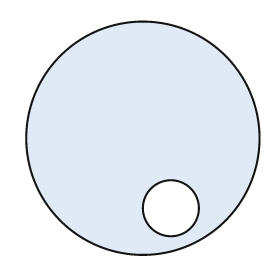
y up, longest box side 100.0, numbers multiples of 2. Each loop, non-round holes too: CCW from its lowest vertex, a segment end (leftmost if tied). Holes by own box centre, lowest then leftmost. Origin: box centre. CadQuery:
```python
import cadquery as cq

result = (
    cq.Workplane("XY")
    .moveTo(0.0, 0.0)
    .circle(50.0)
    .moveTo(12.0, -30.0)
    .circle(12.0)
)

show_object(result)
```